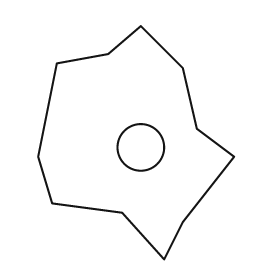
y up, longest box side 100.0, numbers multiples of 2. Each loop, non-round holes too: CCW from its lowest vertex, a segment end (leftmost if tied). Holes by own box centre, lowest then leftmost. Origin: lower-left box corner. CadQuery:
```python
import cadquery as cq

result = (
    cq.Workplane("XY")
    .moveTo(54.0, 0.0)
    .lineTo(62.0, 16.0)
    .lineTo(84.0, 44.0)
    .lineTo(68.0, 56.0)
    .lineTo(62.0, 82.0)
    .lineTo(44.0, 100.0)
    .lineTo(30.0, 88.0)
    .lineTo(8.0, 84.0)
    .lineTo(0.0, 44.0)
    .lineTo(6.0, 24.0)
    .lineTo(36.0, 20.0)
    .close()
    .moveTo(44.0, 48.0)
    .circle(10.0)
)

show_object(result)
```